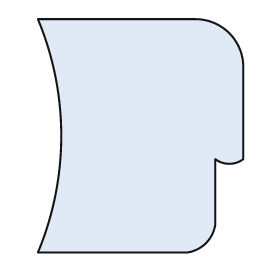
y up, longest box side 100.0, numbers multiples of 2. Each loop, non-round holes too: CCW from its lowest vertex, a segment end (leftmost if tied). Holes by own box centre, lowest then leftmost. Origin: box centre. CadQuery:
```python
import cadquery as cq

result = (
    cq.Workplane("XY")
    .moveTo(-44.0, -50.0)
    .lineTo(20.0, -50.0)
    .threePointArc((28.0, -46.0), (32.0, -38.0))
    .lineTo(32.0, -10.0)
    .threePointArc((38.0, -12.0), (44.0, -10.0))
    .lineTo(44.0, 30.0)
    .threePointArc((38.0, 44.0), (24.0, 50.0))
    .lineTo(-44.0, 50.0)
    .threePointArc((-34.0, 0.0), (-44.0, -50.0))
    .close()
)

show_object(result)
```